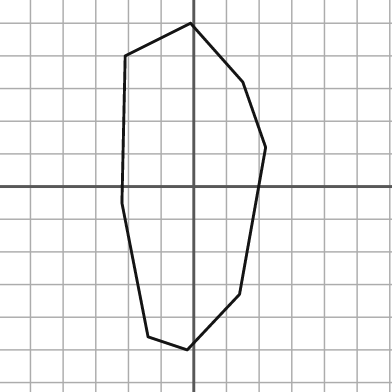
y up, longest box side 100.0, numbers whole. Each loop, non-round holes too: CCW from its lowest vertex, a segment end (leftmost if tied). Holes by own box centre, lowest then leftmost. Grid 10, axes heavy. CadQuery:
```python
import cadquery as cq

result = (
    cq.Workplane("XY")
    .moveTo(-2.0, -50.0)
    .lineTo(14.0, -33.0)
    .lineTo(22.0, 12.0)
    .lineTo(15.0, 32.0)
    .lineTo(-1.0, 50.0)
    .lineTo(-21.0, 40.0)
    .lineTo(-22.0, -5.0)
    .lineTo(-14.0, -46.0)
    .close()
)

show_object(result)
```